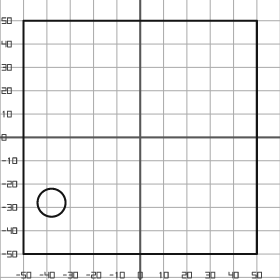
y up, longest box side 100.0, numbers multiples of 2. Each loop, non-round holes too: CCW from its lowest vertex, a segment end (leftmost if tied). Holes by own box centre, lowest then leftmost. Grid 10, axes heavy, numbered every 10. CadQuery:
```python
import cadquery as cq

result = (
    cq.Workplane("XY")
    .moveTo(-50.0, -50.0)
    .lineTo(50.0, -50.0)
    .lineTo(50.0, 50.0)
    .lineTo(-50.0, 50.0)
    .close()
    .moveTo(-38.0, -28.0)
    .circle(6.0)
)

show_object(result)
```